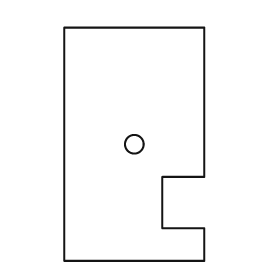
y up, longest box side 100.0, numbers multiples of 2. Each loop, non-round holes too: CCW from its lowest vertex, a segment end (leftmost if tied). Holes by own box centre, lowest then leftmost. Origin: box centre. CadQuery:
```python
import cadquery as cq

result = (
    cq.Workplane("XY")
    .moveTo(-30.0, -50.0)
    .lineTo(30.0, -50.0)
    .lineTo(30.0, -36.0)
    .lineTo(12.0, -36.0)
    .lineTo(12.0, -14.0)
    .lineTo(30.0, -14.0)
    .lineTo(30.0, 50.0)
    .lineTo(-30.0, 50.0)
    .close()
    .moveTo(0.0, 0.0)
    .circle(4.0)
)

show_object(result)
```